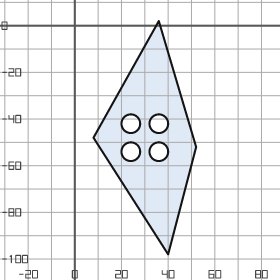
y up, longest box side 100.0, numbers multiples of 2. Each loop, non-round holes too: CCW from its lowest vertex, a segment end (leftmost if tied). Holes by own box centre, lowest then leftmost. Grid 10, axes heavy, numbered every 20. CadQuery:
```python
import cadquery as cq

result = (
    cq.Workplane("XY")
    .moveTo(40.0, -98.0)
    .lineTo(52.0, -52.0)
    .lineTo(36.0, 2.0)
    .lineTo(8.0, -48.0)
    .close()
    .moveTo(24.0, -54.0)
    .circle(4.0)
    .moveTo(36.0, -54.0)
    .circle(4.0)
    .moveTo(24.0, -42.0)
    .circle(4.0)
    .moveTo(36.0, -42.0)
    .circle(4.0)
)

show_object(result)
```